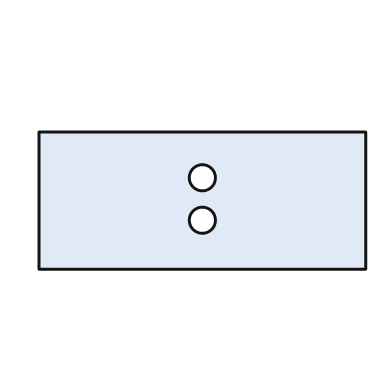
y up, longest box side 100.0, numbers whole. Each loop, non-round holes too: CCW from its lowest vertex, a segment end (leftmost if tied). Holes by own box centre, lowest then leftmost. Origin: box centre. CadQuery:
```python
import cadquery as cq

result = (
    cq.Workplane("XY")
    .moveTo(-50.0, -21.0)
    .lineTo(50.0, -21.0)
    .lineTo(50.0, 21.0)
    .lineTo(-50.0, 21.0)
    .close()
    .moveTo(0.0, -6.0)
    .circle(4.0)
    .moveTo(0.0, 7.0)
    .circle(4.0)
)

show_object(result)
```